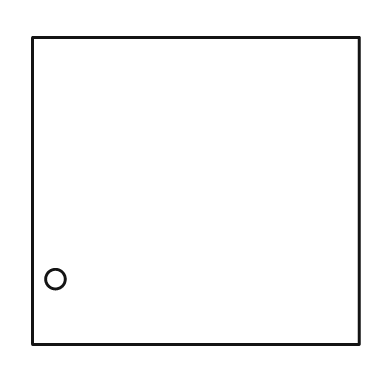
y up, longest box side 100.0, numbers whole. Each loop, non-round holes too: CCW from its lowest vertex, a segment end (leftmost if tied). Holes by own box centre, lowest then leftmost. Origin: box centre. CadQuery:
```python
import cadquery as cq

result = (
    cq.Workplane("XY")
    .moveTo(-50.0, -47.0)
    .lineTo(50.0, -47.0)
    .lineTo(50.0, 47.0)
    .lineTo(-50.0, 47.0)
    .close()
    .moveTo(-43.0, -27.0)
    .circle(3.0)
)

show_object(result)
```